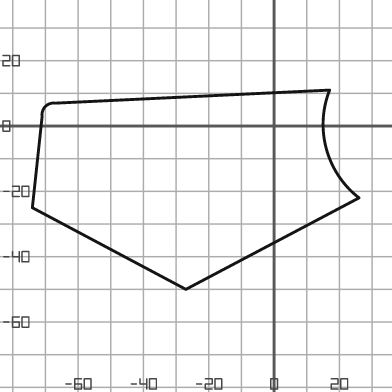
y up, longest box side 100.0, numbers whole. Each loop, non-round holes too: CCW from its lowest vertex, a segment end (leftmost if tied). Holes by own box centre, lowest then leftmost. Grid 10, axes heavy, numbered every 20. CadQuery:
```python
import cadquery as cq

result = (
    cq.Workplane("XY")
    .moveTo(-27.0, -50.0)
    .lineTo(26.0, -22.0)
    .threePointArc((16.0, -7.0), (17.0, 11.0))
    .lineTo(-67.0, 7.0)
    .threePointArc((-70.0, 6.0), (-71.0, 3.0))
    .lineTo(-74.0, -25.0)
    .close()
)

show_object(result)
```